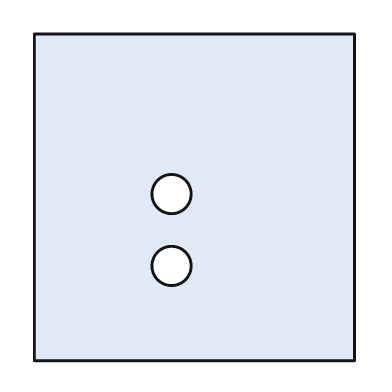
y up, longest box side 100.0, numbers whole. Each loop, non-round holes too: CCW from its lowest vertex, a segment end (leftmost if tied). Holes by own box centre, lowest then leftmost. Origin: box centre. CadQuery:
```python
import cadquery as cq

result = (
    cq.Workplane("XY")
    .moveTo(-49.0, -50.0)
    .lineTo(49.0, -50.0)
    .lineTo(49.0, 50.0)
    .lineTo(-49.0, 50.0)
    .close()
    .moveTo(-7.0, -21.0)
    .circle(6.0)
    .moveTo(-7.0, 1.0)
    .circle(6.0)
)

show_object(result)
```